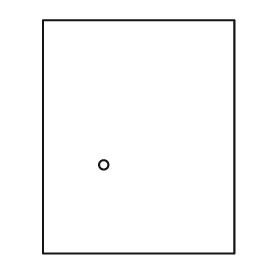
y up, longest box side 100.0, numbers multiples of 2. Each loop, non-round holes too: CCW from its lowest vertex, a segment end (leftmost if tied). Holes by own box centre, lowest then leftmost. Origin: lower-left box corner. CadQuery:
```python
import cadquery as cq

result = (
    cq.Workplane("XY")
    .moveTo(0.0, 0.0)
    .lineTo(82.0, 0.0)
    .lineTo(82.0, 100.0)
    .lineTo(0.0, 100.0)
    .close()
    .moveTo(26.0, 38.0)
    .circle(2.0)
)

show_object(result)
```